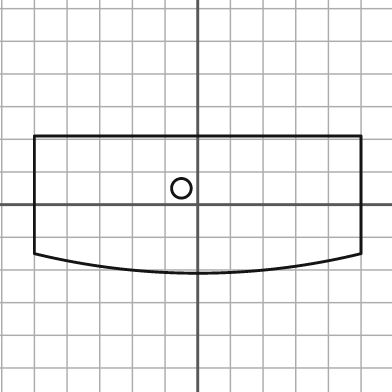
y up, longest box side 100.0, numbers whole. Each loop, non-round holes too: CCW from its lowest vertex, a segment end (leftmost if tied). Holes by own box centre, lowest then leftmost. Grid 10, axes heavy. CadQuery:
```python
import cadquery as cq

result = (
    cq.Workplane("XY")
    .moveTo(-50.0, -15.0)
    .threePointArc((0.0, -21.0), (50.0, -15.0))
    .lineTo(50.0, 21.0)
    .lineTo(-50.0, 21.0)
    .close()
    .moveTo(-5.0, 5.0)
    .circle(3.0)
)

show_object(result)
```